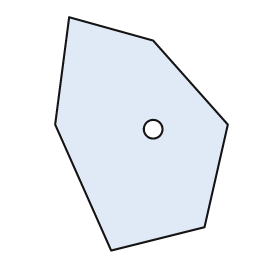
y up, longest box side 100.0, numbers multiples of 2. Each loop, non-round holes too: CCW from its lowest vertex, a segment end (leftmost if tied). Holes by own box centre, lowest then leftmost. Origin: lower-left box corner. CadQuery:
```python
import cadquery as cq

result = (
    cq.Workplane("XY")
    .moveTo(24.0, 0.0)
    .lineTo(64.0, 10.0)
    .lineTo(74.0, 54.0)
    .lineTo(42.0, 90.0)
    .lineTo(6.0, 100.0)
    .lineTo(0.0, 54.0)
    .close()
    .moveTo(42.0, 52.0)
    .circle(4.0)
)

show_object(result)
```